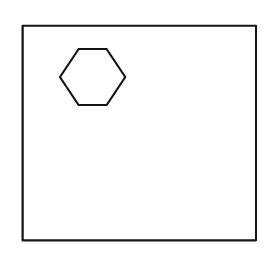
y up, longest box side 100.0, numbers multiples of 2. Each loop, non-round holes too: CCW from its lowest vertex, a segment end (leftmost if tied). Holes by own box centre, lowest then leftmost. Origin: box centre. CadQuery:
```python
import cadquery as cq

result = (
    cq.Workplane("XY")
    .moveTo(-50.0, -46.0)
    .lineTo(50.0, -46.0)
    .lineTo(50.0, 46.0)
    .lineTo(-50.0, 46.0)
    .close()
    .moveTo(-26.0, 12.0)
    .lineTo(-14.0, 12.0)
    .lineTo(-6.0, 24.0)
    .lineTo(-14.0, 36.0)
    .lineTo(-26.0, 36.0)
    .lineTo(-34.0, 24.0)
    .close()
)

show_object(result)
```